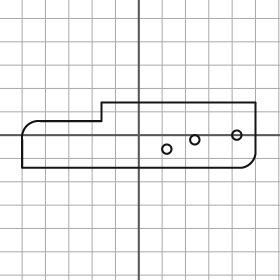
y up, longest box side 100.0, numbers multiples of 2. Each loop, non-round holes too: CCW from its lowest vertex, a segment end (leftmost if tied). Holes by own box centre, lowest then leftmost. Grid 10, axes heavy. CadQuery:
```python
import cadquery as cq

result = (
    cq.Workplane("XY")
    .moveTo(-50.0, -14.0)
    .lineTo(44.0, -14.0)
    .threePointArc((48.0, -12.0), (50.0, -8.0))
    .lineTo(50.0, 14.0)
    .lineTo(-16.0, 14.0)
    .lineTo(-16.0, 6.0)
    .lineTo(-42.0, 6.0)
    .threePointArc((-48.0, 4.0), (-50.0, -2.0))
    .close()
    .moveTo(12.0, -6.0)
    .circle(2.0)
    .moveTo(24.0, -2.0)
    .circle(2.0)
    .moveTo(42.0, 0.0)
    .circle(2.0)
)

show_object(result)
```